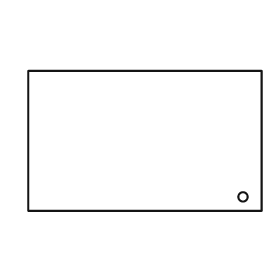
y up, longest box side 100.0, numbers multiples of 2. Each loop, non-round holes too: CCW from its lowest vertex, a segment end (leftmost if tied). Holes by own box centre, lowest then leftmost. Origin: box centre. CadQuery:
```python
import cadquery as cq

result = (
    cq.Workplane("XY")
    .moveTo(-50.0, -30.0)
    .lineTo(50.0, -30.0)
    .lineTo(50.0, 30.0)
    .lineTo(-50.0, 30.0)
    .close()
    .moveTo(42.0, -24.0)
    .circle(2.0)
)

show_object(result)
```